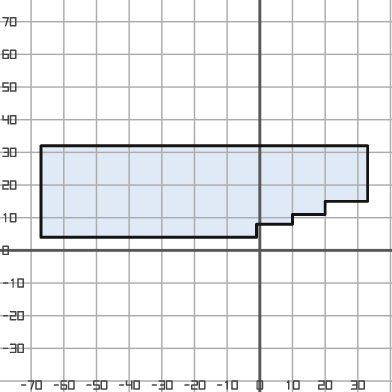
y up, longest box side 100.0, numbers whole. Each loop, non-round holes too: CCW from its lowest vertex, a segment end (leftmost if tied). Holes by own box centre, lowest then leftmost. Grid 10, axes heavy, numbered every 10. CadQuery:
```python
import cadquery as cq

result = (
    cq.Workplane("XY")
    .moveTo(-67.0, 4.0)
    .lineTo(-1.0, 4.0)
    .lineTo(-1.0, 8.0)
    .lineTo(10.0, 8.0)
    .lineTo(10.0, 11.0)
    .lineTo(20.0, 11.0)
    .lineTo(20.0, 15.0)
    .lineTo(33.0, 15.0)
    .lineTo(33.0, 32.0)
    .lineTo(-67.0, 32.0)
    .close()
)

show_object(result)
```